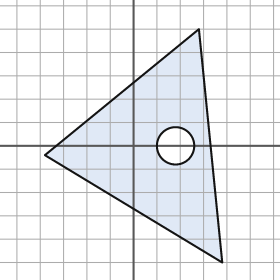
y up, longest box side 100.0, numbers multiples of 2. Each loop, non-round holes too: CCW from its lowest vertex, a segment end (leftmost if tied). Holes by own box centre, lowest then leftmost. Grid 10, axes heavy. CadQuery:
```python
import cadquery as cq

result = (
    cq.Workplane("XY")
    .moveTo(38.0, -50.0)
    .lineTo(28.0, 50.0)
    .lineTo(-38.0, -4.0)
    .close()
    .moveTo(18.0, 0.0)
    .circle(8.0)
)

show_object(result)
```